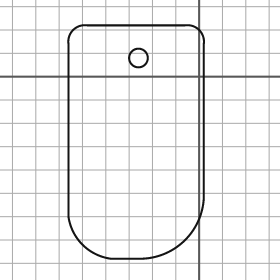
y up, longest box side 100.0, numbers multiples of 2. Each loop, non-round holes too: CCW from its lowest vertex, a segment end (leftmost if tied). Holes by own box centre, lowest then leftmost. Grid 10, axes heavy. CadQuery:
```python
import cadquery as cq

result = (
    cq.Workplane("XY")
    .moveTo(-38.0, -78.0)
    .lineTo(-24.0, -78.0)
    .threePointArc((-6.0, -70.0), (2.0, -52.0))
    .lineTo(2.0, 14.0)
    .threePointArc((0.0, 20.0), (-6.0, 22.0))
    .lineTo(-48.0, 22.0)
    .threePointArc((-54.0, 20.0), (-56.0, 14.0))
    .lineTo(-56.0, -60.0)
    .threePointArc((-50.0, -72.0), (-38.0, -78.0))
    .close()
    .moveTo(-26.0, 8.0)
    .circle(4.0)
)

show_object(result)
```